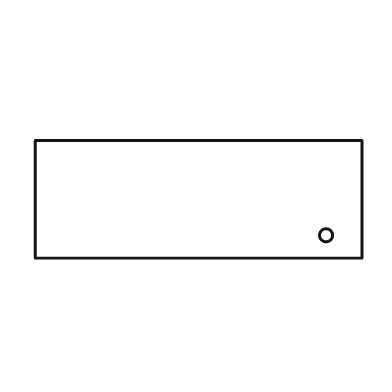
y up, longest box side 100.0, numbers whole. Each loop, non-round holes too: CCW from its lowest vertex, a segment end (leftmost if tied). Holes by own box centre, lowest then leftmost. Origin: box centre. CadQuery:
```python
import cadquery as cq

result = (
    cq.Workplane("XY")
    .moveTo(-50.0, -18.0)
    .lineTo(50.0, -18.0)
    .lineTo(50.0, 18.0)
    .lineTo(-50.0, 18.0)
    .close()
    .moveTo(39.0, -11.0)
    .circle(2.0)
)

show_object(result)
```